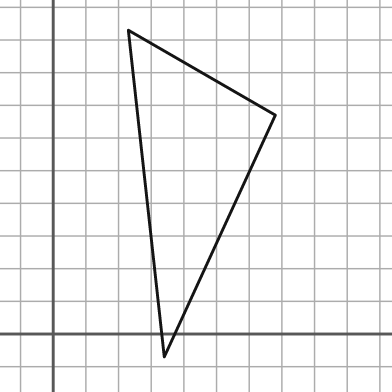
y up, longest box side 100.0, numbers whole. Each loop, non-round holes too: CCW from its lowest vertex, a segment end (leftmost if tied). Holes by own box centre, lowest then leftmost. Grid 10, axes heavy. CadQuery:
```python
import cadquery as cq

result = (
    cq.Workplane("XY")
    .moveTo(34.0, -7.0)
    .lineTo(68.0, 67.0)
    .lineTo(23.0, 93.0)
    .close()
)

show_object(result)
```